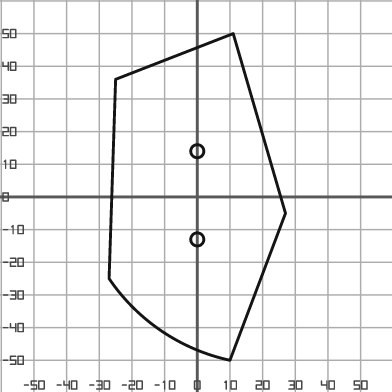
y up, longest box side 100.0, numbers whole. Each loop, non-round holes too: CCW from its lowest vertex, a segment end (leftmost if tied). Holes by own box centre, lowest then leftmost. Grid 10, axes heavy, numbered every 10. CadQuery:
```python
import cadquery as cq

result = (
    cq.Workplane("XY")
    .moveTo(10.0, -50.0)
    .lineTo(27.0, -5.0)
    .lineTo(11.0, 50.0)
    .lineTo(-25.0, 36.0)
    .lineTo(-27.0, -25.0)
    .threePointArc((-11.0, -41.0), (10.0, -50.0))
    .close()
    .moveTo(0.0, -13.0)
    .circle(2.0)
    .moveTo(0.0, 14.0)
    .circle(2.0)
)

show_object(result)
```